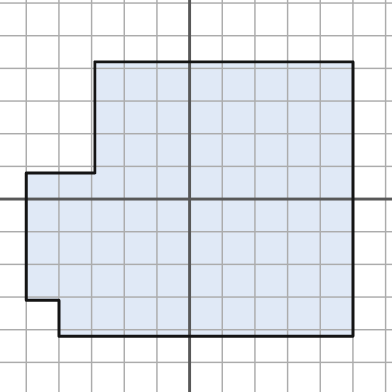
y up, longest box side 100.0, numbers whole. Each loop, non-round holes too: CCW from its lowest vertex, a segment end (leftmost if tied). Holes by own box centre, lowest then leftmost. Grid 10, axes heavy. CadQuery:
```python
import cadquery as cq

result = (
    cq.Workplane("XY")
    .moveTo(-40.0, -42.0)
    .lineTo(50.0, -42.0)
    .lineTo(50.0, 42.0)
    .lineTo(-29.0, 42.0)
    .lineTo(-29.0, 8.0)
    .lineTo(-50.0, 8.0)
    .lineTo(-50.0, -31.0)
    .lineTo(-40.0, -31.0)
    .close()
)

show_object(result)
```